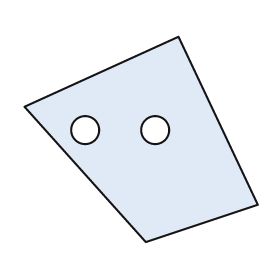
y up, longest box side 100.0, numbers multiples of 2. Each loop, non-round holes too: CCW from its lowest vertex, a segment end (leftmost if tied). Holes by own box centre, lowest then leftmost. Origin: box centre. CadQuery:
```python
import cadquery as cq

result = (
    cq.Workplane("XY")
    .moveTo(2.0, -44.0)
    .lineTo(50.0, -28.0)
    .lineTo(16.0, 44.0)
    .lineTo(-50.0, 14.0)
    .close()
    .moveTo(-24.0, 4.0)
    .circle(6.0)
    .moveTo(6.0, 4.0)
    .circle(6.0)
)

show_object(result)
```